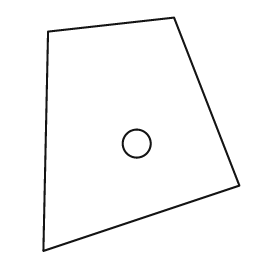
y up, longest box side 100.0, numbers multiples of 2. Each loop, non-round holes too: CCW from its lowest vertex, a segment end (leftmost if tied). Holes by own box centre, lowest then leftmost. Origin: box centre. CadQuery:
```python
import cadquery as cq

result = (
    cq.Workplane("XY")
    .moveTo(-42.0, -50.0)
    .lineTo(42.0, -22.0)
    .lineTo(14.0, 50.0)
    .lineTo(-40.0, 44.0)
    .close()
    .moveTo(-2.0, -4.0)
    .circle(6.0)
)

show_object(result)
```